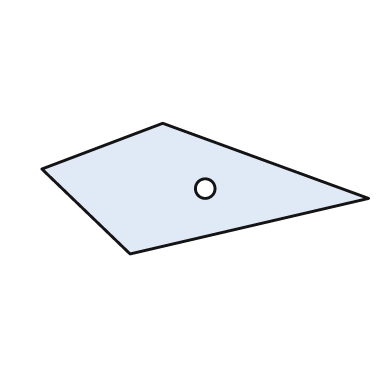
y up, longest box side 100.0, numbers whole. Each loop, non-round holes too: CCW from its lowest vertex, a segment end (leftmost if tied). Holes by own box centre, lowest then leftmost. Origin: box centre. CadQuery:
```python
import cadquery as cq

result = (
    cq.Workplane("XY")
    .moveTo(-23.0, -20.0)
    .lineTo(50.0, -3.0)
    .lineTo(-13.0, 20.0)
    .lineTo(-50.0, 6.0)
    .close()
    .moveTo(0.0, 0.0)
    .circle(3.0)
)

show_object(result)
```